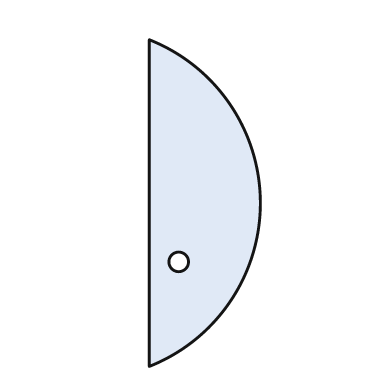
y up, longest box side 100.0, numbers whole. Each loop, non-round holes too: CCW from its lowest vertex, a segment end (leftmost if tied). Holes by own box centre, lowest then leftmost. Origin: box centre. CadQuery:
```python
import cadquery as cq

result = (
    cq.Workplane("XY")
    .moveTo(-17.0, -50.0)
    .threePointArc((17.0, 0.0), (-17.0, 50.0))
    .close()
    .moveTo(-8.0, -18.0)
    .circle(3.0)
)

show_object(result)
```